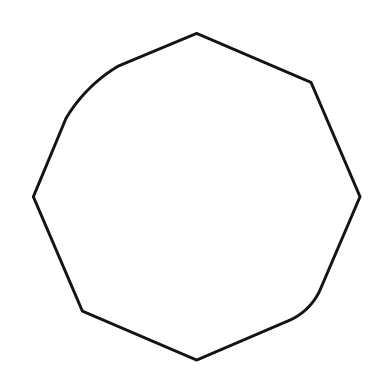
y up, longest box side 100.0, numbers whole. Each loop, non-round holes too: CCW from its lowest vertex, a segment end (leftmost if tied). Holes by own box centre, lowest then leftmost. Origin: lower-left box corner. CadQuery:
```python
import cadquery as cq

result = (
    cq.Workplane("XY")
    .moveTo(50.0, 0.0)
    .lineTo(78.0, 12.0)
    .threePointArc((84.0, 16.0), (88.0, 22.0))
    .lineTo(100.0, 50.0)
    .lineTo(85.0, 85.0)
    .lineTo(50.0, 100.0)
    .lineTo(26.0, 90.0)
    .threePointArc((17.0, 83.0), (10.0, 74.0))
    .lineTo(0.0, 50.0)
    .lineTo(15.0, 15.0)
    .close()
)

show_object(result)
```